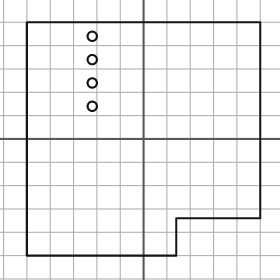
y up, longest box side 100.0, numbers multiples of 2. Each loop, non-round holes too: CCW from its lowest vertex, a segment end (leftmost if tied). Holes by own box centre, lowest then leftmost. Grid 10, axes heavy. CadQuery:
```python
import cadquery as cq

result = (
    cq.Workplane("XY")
    .moveTo(-50.0, -50.0)
    .lineTo(14.0, -50.0)
    .lineTo(14.0, -34.0)
    .lineTo(50.0, -34.0)
    .lineTo(50.0, 50.0)
    .lineTo(-50.0, 50.0)
    .close()
    .moveTo(-22.0, 14.0)
    .circle(2.0)
    .moveTo(-22.0, 24.0)
    .circle(2.0)
    .moveTo(-22.0, 34.0)
    .circle(2.0)
    .moveTo(-22.0, 44.0)
    .circle(2.0)
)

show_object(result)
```